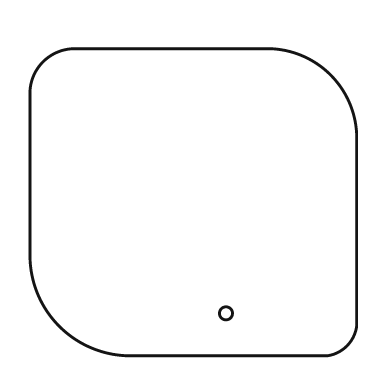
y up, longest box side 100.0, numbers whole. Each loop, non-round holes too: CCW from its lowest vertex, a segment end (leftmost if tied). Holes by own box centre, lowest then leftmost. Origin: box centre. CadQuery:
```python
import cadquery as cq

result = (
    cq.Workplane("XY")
    .moveTo(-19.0, -47.0)
    .lineTo(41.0, -47.0)
    .threePointArc((47.0, -44.0), (50.0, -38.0))
    .lineTo(50.0, 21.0)
    .threePointArc((42.0, 39.0), (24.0, 47.0))
    .lineTo(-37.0, 47.0)
    .threePointArc((-46.0, 43.0), (-50.0, 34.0))
    .lineTo(-50.0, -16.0)
    .threePointArc((-41.0, -38.0), (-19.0, -47.0))
    .close()
    .moveTo(10.0, -34.0)
    .circle(2.0)
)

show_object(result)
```